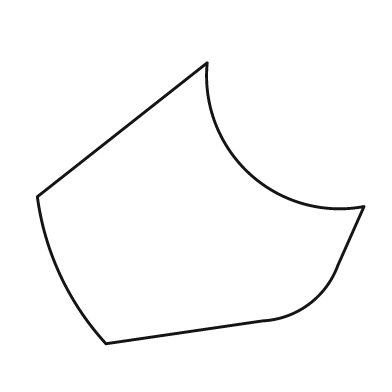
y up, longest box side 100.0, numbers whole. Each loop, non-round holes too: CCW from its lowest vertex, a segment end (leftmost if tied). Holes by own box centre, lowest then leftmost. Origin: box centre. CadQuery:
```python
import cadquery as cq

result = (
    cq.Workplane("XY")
    .moveTo(-29.0, -43.0)
    .lineTo(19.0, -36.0)
    .threePointArc((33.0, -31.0), (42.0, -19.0))
    .lineTo(50.0, -1.0)
    .threePointArc((15.0, 9.0), (2.0, 43.0))
    .lineTo(-50.0, 2.0)
    .threePointArc((-43.0, -22.0), (-29.0, -43.0))
    .close()
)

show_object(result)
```